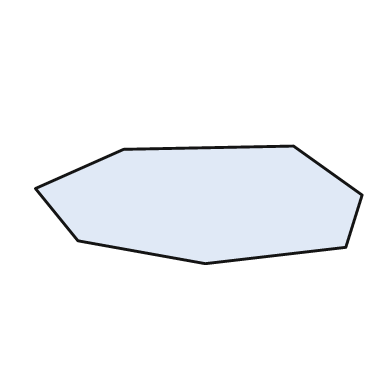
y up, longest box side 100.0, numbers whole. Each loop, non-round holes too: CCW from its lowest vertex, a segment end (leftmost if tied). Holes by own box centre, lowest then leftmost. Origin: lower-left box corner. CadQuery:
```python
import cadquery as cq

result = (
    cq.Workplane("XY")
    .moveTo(52.0, 0.0)
    .lineTo(95.0, 5.0)
    .lineTo(100.0, 21.0)
    .lineTo(79.0, 36.0)
    .lineTo(27.0, 35.0)
    .lineTo(0.0, 23.0)
    .lineTo(13.0, 7.0)
    .close()
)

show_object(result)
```